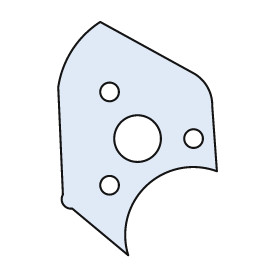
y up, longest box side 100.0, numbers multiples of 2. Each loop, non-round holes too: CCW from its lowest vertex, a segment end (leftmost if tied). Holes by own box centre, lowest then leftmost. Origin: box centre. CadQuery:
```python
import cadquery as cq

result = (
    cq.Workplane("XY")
    .moveTo(-4.0, -50.0)
    .threePointArc((4.0, -20.0), (34.0, -14.0))
    .lineTo(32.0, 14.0)
    .threePointArc((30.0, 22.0), (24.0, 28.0))
    .lineTo(-16.0, 50.0)
    .threePointArc((-28.0, 38.0), (-34.0, 22.0))
    .lineTo(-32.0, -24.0)
    .threePointArc((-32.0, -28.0), (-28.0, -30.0))
    .close()
    .moveTo(-12.0, -20.0)
    .circle(4.0)
    .moveTo(0.0, 0.0)
    .circle(10.0)
    .moveTo(24.0, 0.0)
    .circle(4.0)
    .moveTo(-12.0, 20.0)
    .circle(4.0)
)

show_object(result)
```